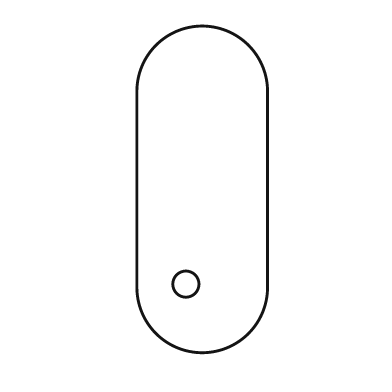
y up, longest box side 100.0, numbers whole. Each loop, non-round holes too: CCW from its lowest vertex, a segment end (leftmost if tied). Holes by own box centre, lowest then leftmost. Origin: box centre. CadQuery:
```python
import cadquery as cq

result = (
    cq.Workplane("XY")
    .moveTo(-20.0, -30.0)
    .threePointArc((0.0, -50.0), (20.0, -30.0))
    .lineTo(20.0, 30.0)
    .threePointArc((0.0, 50.0), (-20.0, 30.0))
    .close()
    .moveTo(-5.0, -29.0)
    .circle(4.0)
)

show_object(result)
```